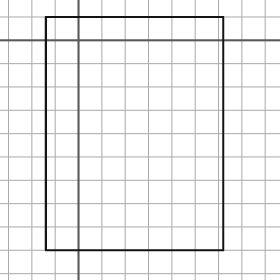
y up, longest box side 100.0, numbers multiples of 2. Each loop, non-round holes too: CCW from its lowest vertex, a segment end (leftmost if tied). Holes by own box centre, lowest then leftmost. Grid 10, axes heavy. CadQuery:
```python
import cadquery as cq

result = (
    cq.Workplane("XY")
    .moveTo(-14.0, -90.0)
    .lineTo(62.0, -90.0)
    .lineTo(62.0, 10.0)
    .lineTo(-14.0, 10.0)
    .close()
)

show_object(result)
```